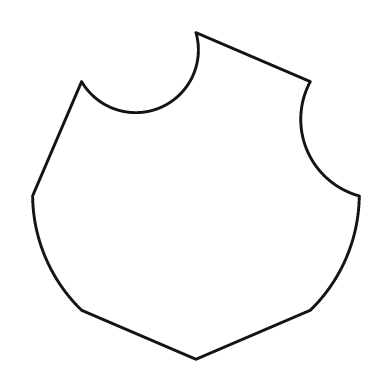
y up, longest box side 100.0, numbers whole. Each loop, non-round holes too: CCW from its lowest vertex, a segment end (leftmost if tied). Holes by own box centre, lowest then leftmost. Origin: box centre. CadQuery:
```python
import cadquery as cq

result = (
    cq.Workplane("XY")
    .moveTo(0.0, -50.0)
    .lineTo(35.0, -35.0)
    .threePointArc((46.0, -19.0), (50.0, 0.0))
    .threePointArc((34.0, 14.0), (35.0, 35.0))
    .lineTo(0.0, 50.0)
    .threePointArc((-11.0, 27.0), (-35.0, 35.0))
    .lineTo(-50.0, 0.0)
    .threePointArc((-46.0, -19.0), (-35.0, -35.0))
    .close()
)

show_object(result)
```